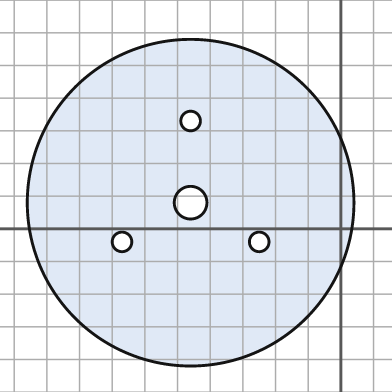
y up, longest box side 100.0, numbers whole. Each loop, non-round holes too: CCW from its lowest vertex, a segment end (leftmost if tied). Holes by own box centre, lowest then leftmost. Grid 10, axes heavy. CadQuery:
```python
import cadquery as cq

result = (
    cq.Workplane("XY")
    .moveTo(-46.0, 8.0)
    .circle(50.0)
    .moveTo(-67.0, -4.0)
    .circle(3.0)
    .moveTo(-25.0, -4.0)
    .circle(3.0)
    .moveTo(-46.0, 8.0)
    .circle(5.0)
    .moveTo(-46.0, 33.0)
    .circle(3.0)
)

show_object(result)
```